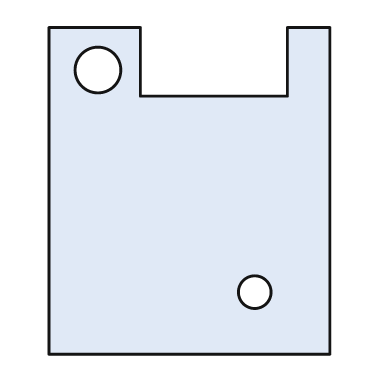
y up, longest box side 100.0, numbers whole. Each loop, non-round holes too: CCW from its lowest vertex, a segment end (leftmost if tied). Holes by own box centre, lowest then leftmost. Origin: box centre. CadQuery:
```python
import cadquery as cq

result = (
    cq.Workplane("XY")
    .moveTo(-43.0, -50.0)
    .lineTo(43.0, -50.0)
    .lineTo(43.0, 50.0)
    .lineTo(30.0, 50.0)
    .lineTo(30.0, 29.0)
    .lineTo(-15.0, 29.0)
    .lineTo(-15.0, 50.0)
    .lineTo(-43.0, 50.0)
    .close()
    .moveTo(20.0, -31.0)
    .circle(5.0)
    .moveTo(-28.0, 37.0)
    .circle(7.0)
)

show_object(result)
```